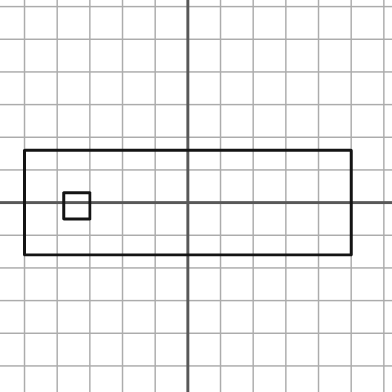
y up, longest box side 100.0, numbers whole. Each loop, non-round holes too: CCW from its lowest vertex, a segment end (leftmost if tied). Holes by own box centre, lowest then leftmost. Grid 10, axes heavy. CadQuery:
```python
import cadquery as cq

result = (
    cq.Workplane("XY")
    .moveTo(-50.0, -16.0)
    .lineTo(50.0, -16.0)
    .lineTo(50.0, 16.0)
    .lineTo(-50.0, 16.0)
    .close()
    .moveTo(-38.0, -5.0)
    .lineTo(-30.0, -5.0)
    .lineTo(-30.0, 3.0)
    .lineTo(-38.0, 3.0)
    .close()
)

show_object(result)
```